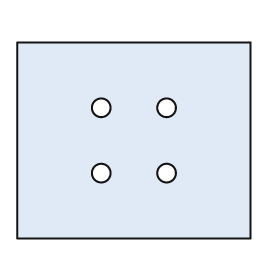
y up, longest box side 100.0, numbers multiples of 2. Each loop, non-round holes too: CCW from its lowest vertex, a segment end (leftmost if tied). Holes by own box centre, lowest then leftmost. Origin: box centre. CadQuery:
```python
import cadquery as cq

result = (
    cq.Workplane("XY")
    .moveTo(-50.0, -42.0)
    .lineTo(50.0, -42.0)
    .lineTo(50.0, 42.0)
    .lineTo(-50.0, 42.0)
    .close()
    .moveTo(-14.0, -14.0)
    .circle(4.0)
    .moveTo(14.0, -14.0)
    .circle(4.0)
    .moveTo(-14.0, 14.0)
    .circle(4.0)
    .moveTo(14.0, 14.0)
    .circle(4.0)
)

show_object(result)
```